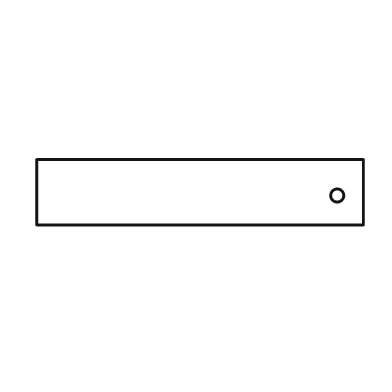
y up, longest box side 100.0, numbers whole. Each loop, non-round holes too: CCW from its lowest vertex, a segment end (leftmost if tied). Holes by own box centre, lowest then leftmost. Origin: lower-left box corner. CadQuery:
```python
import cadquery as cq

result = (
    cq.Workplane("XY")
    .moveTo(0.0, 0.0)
    .lineTo(100.0, 0.0)
    .lineTo(100.0, 20.0)
    .lineTo(0.0, 20.0)
    .close()
    .moveTo(92.0, 9.0)
    .circle(2.0)
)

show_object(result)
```